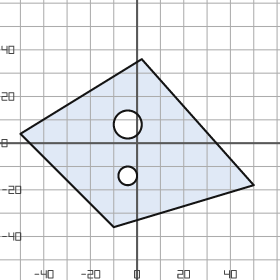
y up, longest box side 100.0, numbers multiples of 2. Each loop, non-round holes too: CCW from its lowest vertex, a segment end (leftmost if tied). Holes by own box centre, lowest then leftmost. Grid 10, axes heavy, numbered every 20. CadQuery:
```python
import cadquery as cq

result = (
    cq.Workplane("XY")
    .moveTo(-10.0, -36.0)
    .lineTo(50.0, -18.0)
    .lineTo(2.0, 36.0)
    .lineTo(-50.0, 4.0)
    .close()
    .moveTo(-4.0, -14.0)
    .circle(4.0)
    .moveTo(-4.0, 8.0)
    .circle(6.0)
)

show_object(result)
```